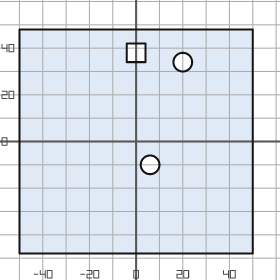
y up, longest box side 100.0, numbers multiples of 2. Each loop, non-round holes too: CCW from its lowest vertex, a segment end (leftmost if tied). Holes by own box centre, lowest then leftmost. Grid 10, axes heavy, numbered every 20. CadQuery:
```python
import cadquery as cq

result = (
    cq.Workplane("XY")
    .moveTo(-50.0, -48.0)
    .lineTo(50.0, -48.0)
    .lineTo(50.0, 48.0)
    .lineTo(-50.0, 48.0)
    .close()
    .moveTo(6.0, -10.0)
    .circle(4.0)
    .moveTo(20.0, 34.0)
    .circle(4.0)
    .moveTo(-4.0, 34.0)
    .lineTo(4.0, 34.0)
    .lineTo(4.0, 42.0)
    .lineTo(-4.0, 42.0)
    .close()
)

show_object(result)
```